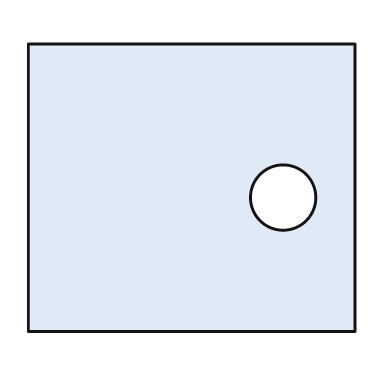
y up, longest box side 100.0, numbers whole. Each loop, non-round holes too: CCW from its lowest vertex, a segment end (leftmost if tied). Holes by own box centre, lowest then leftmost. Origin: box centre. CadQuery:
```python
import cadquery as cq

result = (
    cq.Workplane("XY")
    .moveTo(-50.0, -44.0)
    .lineTo(50.0, -44.0)
    .lineTo(50.0, 44.0)
    .lineTo(-50.0, 44.0)
    .close()
    .moveTo(28.0, -3.0)
    .circle(10.0)
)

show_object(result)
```